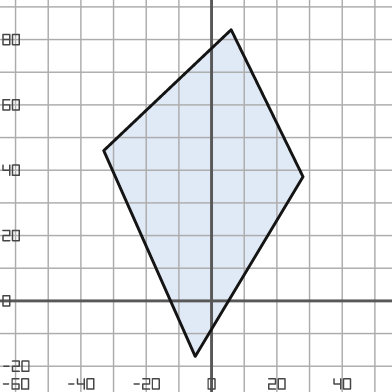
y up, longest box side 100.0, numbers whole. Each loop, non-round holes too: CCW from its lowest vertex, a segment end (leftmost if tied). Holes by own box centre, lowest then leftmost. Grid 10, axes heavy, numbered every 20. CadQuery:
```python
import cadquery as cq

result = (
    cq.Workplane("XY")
    .moveTo(-5.0, -17.0)
    .lineTo(28.0, 38.0)
    .lineTo(6.0, 83.0)
    .lineTo(-33.0, 46.0)
    .close()
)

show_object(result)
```